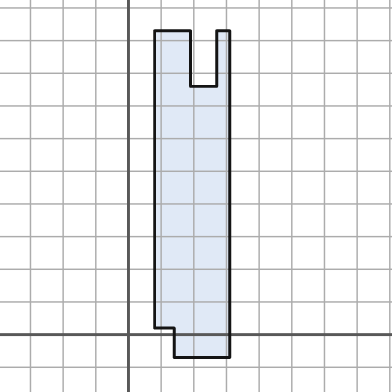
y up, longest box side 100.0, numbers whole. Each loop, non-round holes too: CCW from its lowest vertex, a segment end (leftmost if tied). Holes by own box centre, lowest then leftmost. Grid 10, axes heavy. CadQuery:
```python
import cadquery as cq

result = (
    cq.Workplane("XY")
    .moveTo(14.0, -7.0)
    .lineTo(31.0, -7.0)
    .lineTo(31.0, 93.0)
    .lineTo(27.0, 93.0)
    .lineTo(27.0, 76.0)
    .lineTo(19.0, 76.0)
    .lineTo(19.0, 93.0)
    .lineTo(8.0, 93.0)
    .lineTo(8.0, 2.0)
    .lineTo(14.0, 2.0)
    .close()
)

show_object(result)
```